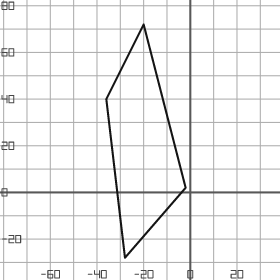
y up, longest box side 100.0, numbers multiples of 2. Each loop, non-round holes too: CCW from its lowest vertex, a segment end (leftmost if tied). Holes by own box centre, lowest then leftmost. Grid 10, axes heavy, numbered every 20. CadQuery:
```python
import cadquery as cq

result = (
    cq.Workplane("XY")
    .moveTo(-28.0, -28.0)
    .lineTo(-2.0, 2.0)
    .lineTo(-20.0, 72.0)
    .lineTo(-36.0, 40.0)
    .close()
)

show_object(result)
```